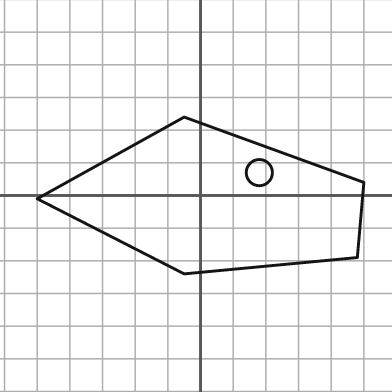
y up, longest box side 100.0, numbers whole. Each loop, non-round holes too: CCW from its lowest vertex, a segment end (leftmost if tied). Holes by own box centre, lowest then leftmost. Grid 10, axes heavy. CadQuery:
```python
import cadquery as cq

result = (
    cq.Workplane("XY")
    .moveTo(-5.0, -24.0)
    .lineTo(48.0, -19.0)
    .lineTo(50.0, 4.0)
    .lineTo(-5.0, 24.0)
    .lineTo(-50.0, -1.0)
    .close()
    .moveTo(18.0, 7.0)
    .circle(4.0)
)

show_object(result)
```